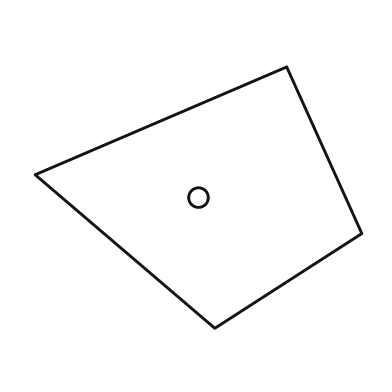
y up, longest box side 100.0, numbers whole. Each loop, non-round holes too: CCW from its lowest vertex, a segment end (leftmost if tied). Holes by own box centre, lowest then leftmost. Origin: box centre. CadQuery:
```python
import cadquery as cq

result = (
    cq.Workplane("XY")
    .moveTo(5.0, -40.0)
    .lineTo(50.0, -11.0)
    .lineTo(27.0, 40.0)
    .lineTo(-50.0, 7.0)
    .close()
    .moveTo(0.0, 0.0)
    .circle(3.0)
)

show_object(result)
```